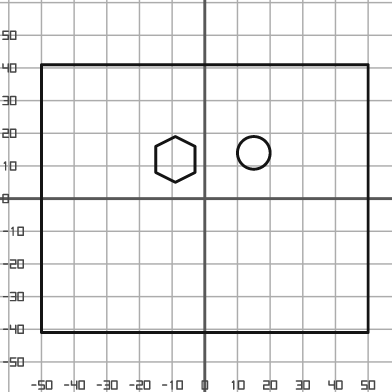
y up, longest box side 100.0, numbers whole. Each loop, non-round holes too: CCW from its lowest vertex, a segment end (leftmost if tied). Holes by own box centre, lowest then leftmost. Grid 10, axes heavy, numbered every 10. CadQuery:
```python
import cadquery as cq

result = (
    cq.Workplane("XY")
    .moveTo(-50.0, -41.0)
    .lineTo(50.0, -41.0)
    .lineTo(50.0, 41.0)
    .lineTo(-50.0, 41.0)
    .close()
    .moveTo(-9.0, 5.0)
    .lineTo(-3.0, 8.0)
    .lineTo(-3.0, 16.0)
    .lineTo(-9.0, 19.0)
    .lineTo(-15.0, 16.0)
    .lineTo(-15.0, 8.0)
    .close()
    .moveTo(15.0, 14.0)
    .circle(5.0)
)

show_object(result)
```